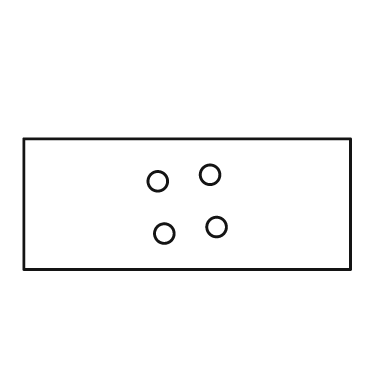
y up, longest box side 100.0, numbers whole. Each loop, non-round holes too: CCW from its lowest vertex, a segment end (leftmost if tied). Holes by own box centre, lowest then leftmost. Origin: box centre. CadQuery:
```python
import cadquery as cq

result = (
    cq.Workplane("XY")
    .moveTo(-50.0, -20.0)
    .lineTo(50.0, -20.0)
    .lineTo(50.0, 20.0)
    .lineTo(-50.0, 20.0)
    .close()
    .moveTo(-7.0, -9.0)
    .circle(3.0)
    .moveTo(9.0, -7.0)
    .circle(3.0)
    .moveTo(-9.0, 7.0)
    .circle(3.0)
    .moveTo(7.0, 9.0)
    .circle(3.0)
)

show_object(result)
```